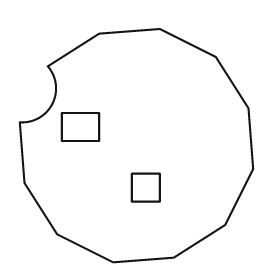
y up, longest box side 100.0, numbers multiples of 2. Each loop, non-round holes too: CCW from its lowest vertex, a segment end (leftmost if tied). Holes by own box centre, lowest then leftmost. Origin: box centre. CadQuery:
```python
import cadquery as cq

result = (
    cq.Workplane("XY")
    .moveTo(-10.0, -50.0)
    .lineTo(16.0, -48.0)
    .lineTo(38.0, -34.0)
    .lineTo(50.0, -10.0)
    .lineTo(48.0, 16.0)
    .lineTo(34.0, 38.0)
    .lineTo(10.0, 50.0)
    .lineTo(-16.0, 48.0)
    .lineTo(-38.0, 34.0)
    .threePointArc((-36.0, 18.0), (-50.0, 10.0))
    .lineTo(-48.0, -16.0)
    .lineTo(-34.0, -38.0)
    .close()
    .moveTo(-2.0, -24.0)
    .lineTo(10.0, -24.0)
    .lineTo(10.0, -12.0)
    .lineTo(-2.0, -12.0)
    .close()
    .moveTo(-32.0, 2.0)
    .lineTo(-16.0, 2.0)
    .lineTo(-16.0, 14.0)
    .lineTo(-32.0, 14.0)
    .close()
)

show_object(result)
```